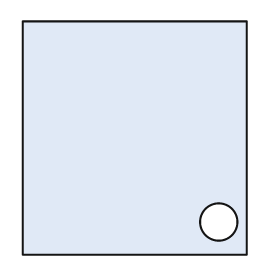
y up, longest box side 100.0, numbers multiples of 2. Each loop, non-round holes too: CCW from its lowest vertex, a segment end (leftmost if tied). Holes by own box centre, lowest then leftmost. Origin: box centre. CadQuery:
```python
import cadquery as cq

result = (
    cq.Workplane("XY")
    .moveTo(-48.0, -50.0)
    .lineTo(48.0, -50.0)
    .lineTo(48.0, 50.0)
    .lineTo(-48.0, 50.0)
    .close()
    .moveTo(36.0, -36.0)
    .circle(8.0)
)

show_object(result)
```